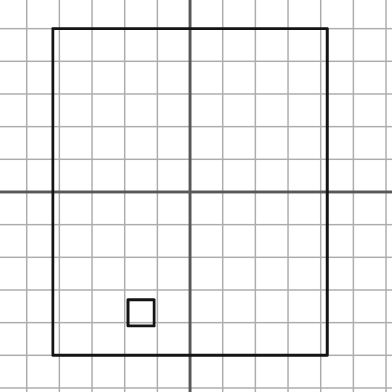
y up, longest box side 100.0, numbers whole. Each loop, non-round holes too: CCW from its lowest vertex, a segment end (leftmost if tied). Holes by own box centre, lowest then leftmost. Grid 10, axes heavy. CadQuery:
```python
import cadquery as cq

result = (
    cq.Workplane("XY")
    .moveTo(-42.0, -50.0)
    .lineTo(42.0, -50.0)
    .lineTo(42.0, 50.0)
    .lineTo(-42.0, 50.0)
    .close()
    .moveTo(-19.0, -41.0)
    .lineTo(-11.0, -41.0)
    .lineTo(-11.0, -33.0)
    .lineTo(-19.0, -33.0)
    .close()
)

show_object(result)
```